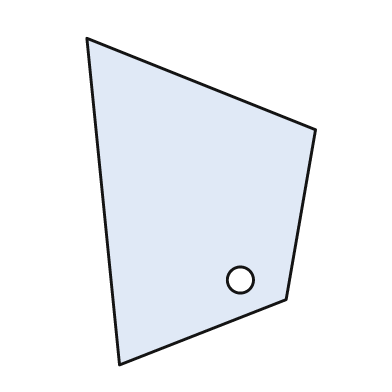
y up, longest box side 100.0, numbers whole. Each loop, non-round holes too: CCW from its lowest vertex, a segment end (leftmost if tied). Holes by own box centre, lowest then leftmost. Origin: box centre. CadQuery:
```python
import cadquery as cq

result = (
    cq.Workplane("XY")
    .moveTo(-25.0, -50.0)
    .lineTo(26.0, -30.0)
    .lineTo(35.0, 22.0)
    .lineTo(-35.0, 50.0)
    .close()
    .moveTo(12.0, -24.0)
    .circle(4.0)
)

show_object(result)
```